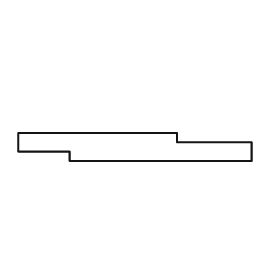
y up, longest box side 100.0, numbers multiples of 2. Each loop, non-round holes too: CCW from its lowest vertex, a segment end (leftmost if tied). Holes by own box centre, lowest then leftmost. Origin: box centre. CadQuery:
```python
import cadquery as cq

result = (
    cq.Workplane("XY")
    .moveTo(-28.0, -6.0)
    .lineTo(50.0, -6.0)
    .lineTo(50.0, 2.0)
    .lineTo(18.0, 2.0)
    .lineTo(18.0, 6.0)
    .lineTo(-50.0, 6.0)
    .lineTo(-50.0, -2.0)
    .lineTo(-28.0, -2.0)
    .close()
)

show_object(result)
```